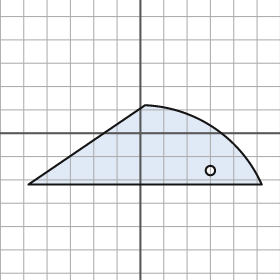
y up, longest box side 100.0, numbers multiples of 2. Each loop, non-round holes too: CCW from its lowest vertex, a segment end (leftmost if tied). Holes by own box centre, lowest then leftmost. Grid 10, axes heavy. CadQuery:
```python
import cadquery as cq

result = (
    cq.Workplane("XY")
    .moveTo(-48.0, -22.0)
    .lineTo(52.0, -22.0)
    .threePointArc((32.0, 2.0), (2.0, 12.0))
    .close()
    .moveTo(30.0, -16.0)
    .circle(2.0)
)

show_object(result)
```